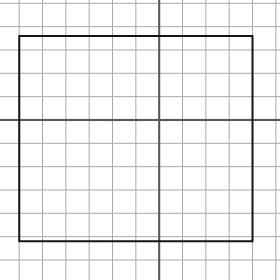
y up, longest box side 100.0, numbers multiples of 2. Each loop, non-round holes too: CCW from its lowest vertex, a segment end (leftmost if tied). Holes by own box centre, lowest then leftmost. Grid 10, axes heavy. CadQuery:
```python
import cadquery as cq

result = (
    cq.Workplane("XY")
    .moveTo(-60.0, -52.0)
    .lineTo(40.0, -52.0)
    .lineTo(40.0, 36.0)
    .lineTo(-60.0, 36.0)
    .close()
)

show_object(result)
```